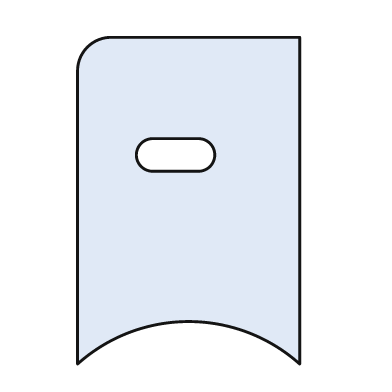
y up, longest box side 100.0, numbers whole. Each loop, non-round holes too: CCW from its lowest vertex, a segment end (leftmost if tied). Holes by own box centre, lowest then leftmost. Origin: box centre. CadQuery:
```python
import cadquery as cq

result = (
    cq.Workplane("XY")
    .moveTo(-34.0, -50.0)
    .threePointArc((0.0, -37.0), (34.0, -50.0))
    .lineTo(34.0, 50.0)
    .lineTo(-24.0, 50.0)
    .threePointArc((-31.0, 47.0), (-34.0, 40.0))
    .close()
    .moveTo(-11.0, 9.0)
    .lineTo(3.0, 9.0)
    .threePointArc((8.0, 14.0), (3.0, 19.0))
    .lineTo(-11.0, 19.0)
    .threePointArc((-16.0, 14.0), (-11.0, 9.0))
    .close()
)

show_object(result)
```